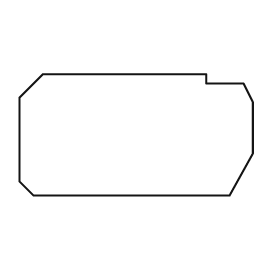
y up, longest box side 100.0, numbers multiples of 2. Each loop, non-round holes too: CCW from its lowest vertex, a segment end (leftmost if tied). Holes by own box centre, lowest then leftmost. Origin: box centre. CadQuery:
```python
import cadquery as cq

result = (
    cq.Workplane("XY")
    .moveTo(-44.0, -26.0)
    .lineTo(40.0, -26.0)
    .lineTo(50.0, -8.0)
    .lineTo(50.0, 14.0)
    .lineTo(46.0, 22.0)
    .lineTo(30.0, 22.0)
    .lineTo(30.0, 26.0)
    .lineTo(-40.0, 26.0)
    .lineTo(-50.0, 16.0)
    .lineTo(-50.0, -20.0)
    .close()
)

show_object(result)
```